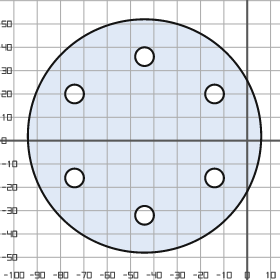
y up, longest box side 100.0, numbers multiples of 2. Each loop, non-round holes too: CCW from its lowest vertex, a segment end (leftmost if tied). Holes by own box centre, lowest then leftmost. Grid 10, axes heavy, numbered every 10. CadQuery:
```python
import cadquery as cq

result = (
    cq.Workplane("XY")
    .moveTo(-44.0, 2.0)
    .circle(50.0)
    .moveTo(-44.0, -32.0)
    .circle(4.0)
    .moveTo(-74.0, -16.0)
    .circle(4.0)
    .moveTo(-14.0, -16.0)
    .circle(4.0)
    .moveTo(-74.0, 20.0)
    .circle(4.0)
    .moveTo(-14.0, 20.0)
    .circle(4.0)
    .moveTo(-44.0, 36.0)
    .circle(4.0)
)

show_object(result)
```